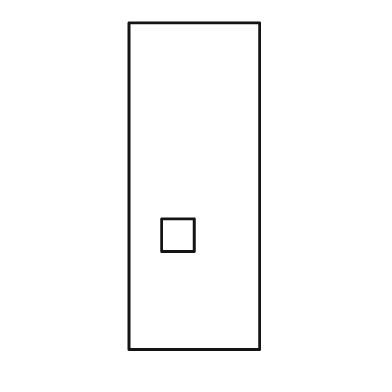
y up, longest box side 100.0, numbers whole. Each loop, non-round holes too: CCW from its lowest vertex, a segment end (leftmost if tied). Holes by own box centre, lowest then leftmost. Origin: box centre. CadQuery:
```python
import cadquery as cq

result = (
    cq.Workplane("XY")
    .moveTo(-20.0, -50.0)
    .lineTo(20.0, -50.0)
    .lineTo(20.0, 50.0)
    .lineTo(-20.0, 50.0)
    .close()
    .moveTo(-10.0, -20.0)
    .lineTo(0.0, -20.0)
    .lineTo(0.0, -10.0)
    .lineTo(-10.0, -10.0)
    .close()
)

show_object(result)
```